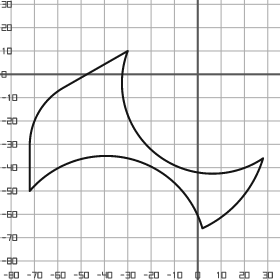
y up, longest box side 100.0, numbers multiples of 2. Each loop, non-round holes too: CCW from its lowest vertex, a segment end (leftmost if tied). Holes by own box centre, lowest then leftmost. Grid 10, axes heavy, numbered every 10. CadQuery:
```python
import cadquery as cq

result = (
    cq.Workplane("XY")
    .moveTo(2.0, -66.0)
    .threePointArc((18.0, -54.0), (28.0, -36.0))
    .threePointArc((-18.0, -34.0), (-30.0, 10.0))
    .lineTo(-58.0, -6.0)
    .threePointArc((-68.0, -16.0), (-72.0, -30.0))
    .lineTo(-72.0, -50.0)
    .threePointArc((-30.0, -36.0), (2.0, -66.0))
    .close()
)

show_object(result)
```